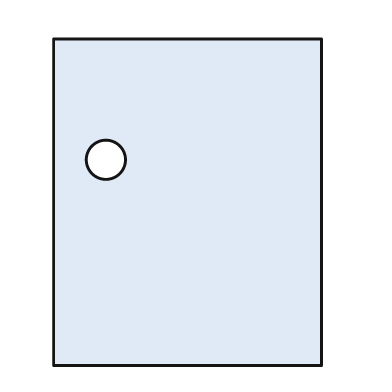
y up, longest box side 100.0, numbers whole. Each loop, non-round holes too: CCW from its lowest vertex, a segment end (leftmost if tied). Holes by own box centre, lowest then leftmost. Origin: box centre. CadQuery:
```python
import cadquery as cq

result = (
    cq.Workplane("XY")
    .moveTo(-41.0, -50.0)
    .lineTo(41.0, -50.0)
    .lineTo(41.0, 50.0)
    .lineTo(-41.0, 50.0)
    .close()
    .moveTo(-25.0, 13.0)
    .circle(6.0)
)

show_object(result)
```